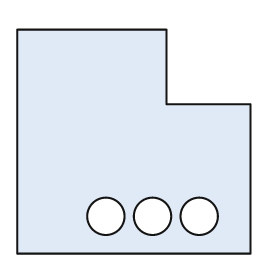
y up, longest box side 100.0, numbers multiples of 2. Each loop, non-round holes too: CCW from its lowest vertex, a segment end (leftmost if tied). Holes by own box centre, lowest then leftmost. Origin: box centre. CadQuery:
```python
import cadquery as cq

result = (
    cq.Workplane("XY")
    .moveTo(-50.0, -48.0)
    .lineTo(50.0, -48.0)
    .lineTo(50.0, 16.0)
    .lineTo(14.0, 16.0)
    .lineTo(14.0, 48.0)
    .lineTo(-50.0, 48.0)
    .close()
    .moveTo(-12.0, -32.0)
    .circle(8.0)
    .moveTo(8.0, -32.0)
    .circle(8.0)
    .moveTo(28.0, -32.0)
    .circle(8.0)
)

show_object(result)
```